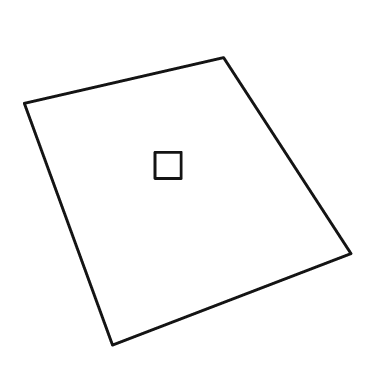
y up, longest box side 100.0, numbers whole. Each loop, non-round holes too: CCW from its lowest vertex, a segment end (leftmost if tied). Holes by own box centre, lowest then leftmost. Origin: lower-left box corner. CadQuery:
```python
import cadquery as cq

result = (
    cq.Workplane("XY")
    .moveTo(27.0, 0.0)
    .lineTo(100.0, 28.0)
    .lineTo(61.0, 88.0)
    .lineTo(0.0, 74.0)
    .close()
    .moveTo(40.0, 51.0)
    .lineTo(48.0, 51.0)
    .lineTo(48.0, 59.0)
    .lineTo(40.0, 59.0)
    .close()
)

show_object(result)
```